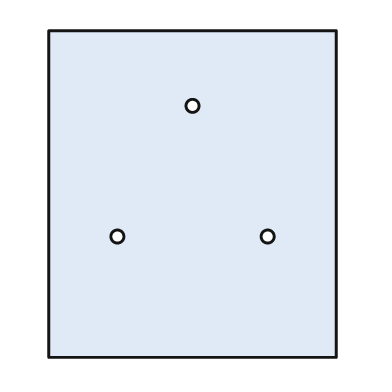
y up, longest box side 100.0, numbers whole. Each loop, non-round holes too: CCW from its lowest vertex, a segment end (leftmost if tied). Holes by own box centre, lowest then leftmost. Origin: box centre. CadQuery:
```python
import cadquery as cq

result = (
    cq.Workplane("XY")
    .moveTo(-44.0, -50.0)
    .lineTo(44.0, -50.0)
    .lineTo(44.0, 50.0)
    .lineTo(-44.0, 50.0)
    .close()
    .moveTo(-23.0, -13.0)
    .circle(2.0)
    .moveTo(23.0, -13.0)
    .circle(2.0)
    .moveTo(0.0, 27.0)
    .circle(2.0)
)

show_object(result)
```